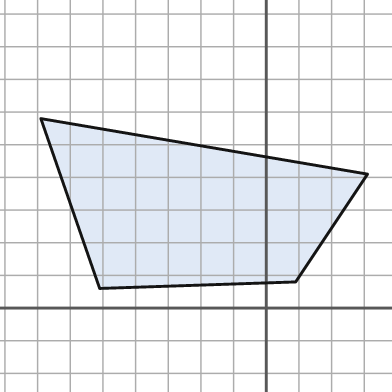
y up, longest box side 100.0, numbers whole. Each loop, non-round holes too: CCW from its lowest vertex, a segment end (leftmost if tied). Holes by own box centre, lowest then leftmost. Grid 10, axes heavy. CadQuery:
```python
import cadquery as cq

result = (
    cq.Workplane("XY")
    .moveTo(-51.0, 6.0)
    .lineTo(9.0, 8.0)
    .lineTo(31.0, 41.0)
    .lineTo(-69.0, 58.0)
    .close()
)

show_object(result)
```